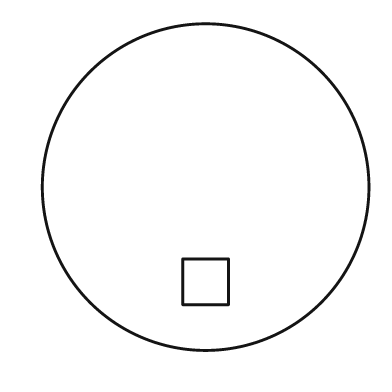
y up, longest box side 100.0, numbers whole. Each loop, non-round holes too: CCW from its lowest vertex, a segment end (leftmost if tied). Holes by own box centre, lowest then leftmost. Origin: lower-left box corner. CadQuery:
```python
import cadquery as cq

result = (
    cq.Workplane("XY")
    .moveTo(50.0, 50.0)
    .circle(50.0)
    .moveTo(43.0, 14.0)
    .lineTo(57.0, 14.0)
    .lineTo(57.0, 28.0)
    .lineTo(43.0, 28.0)
    .close()
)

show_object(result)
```